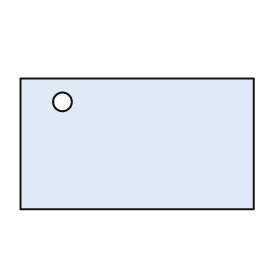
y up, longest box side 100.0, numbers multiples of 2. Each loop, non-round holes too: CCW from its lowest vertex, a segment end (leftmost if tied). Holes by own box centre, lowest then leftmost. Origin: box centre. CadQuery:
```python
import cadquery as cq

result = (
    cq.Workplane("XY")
    .moveTo(-50.0, -28.0)
    .lineTo(50.0, -28.0)
    .lineTo(50.0, 28.0)
    .lineTo(-50.0, 28.0)
    .close()
    .moveTo(-32.0, 18.0)
    .circle(4.0)
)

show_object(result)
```